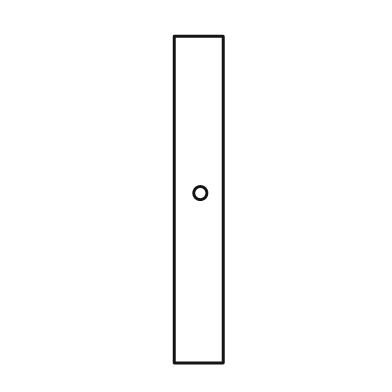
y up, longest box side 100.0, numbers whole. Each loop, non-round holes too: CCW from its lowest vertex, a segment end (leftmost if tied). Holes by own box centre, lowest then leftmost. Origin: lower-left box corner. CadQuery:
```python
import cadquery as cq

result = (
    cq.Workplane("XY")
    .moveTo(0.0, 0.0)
    .lineTo(15.0, 0.0)
    .lineTo(15.0, 100.0)
    .lineTo(0.0, 100.0)
    .close()
    .moveTo(8.0, 52.0)
    .circle(2.0)
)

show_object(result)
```